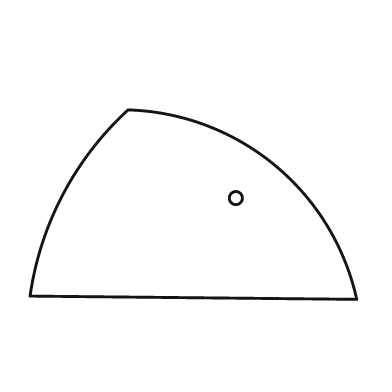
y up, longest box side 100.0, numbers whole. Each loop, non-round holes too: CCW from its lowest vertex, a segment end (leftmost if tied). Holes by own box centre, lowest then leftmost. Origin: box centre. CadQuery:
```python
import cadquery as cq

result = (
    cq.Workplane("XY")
    .moveTo(50.0, -29.0)
    .threePointArc((25.0, 12.0), (-20.0, 29.0))
    .threePointArc((-40.0, 3.0), (-50.0, -28.0))
    .close()
    .moveTo(13.0, 2.0)
    .circle(2.0)
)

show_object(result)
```